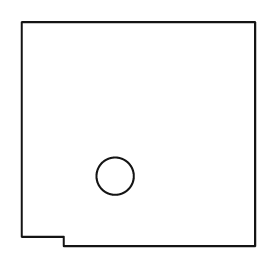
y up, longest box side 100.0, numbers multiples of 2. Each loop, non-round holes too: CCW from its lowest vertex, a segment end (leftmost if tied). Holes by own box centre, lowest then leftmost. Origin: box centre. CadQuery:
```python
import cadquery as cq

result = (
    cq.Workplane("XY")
    .moveTo(-32.0, -48.0)
    .lineTo(50.0, -48.0)
    .lineTo(50.0, 48.0)
    .lineTo(-50.0, 48.0)
    .lineTo(-50.0, -44.0)
    .lineTo(-32.0, -44.0)
    .close()
    .moveTo(-10.0, -18.0)
    .circle(8.0)
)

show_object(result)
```